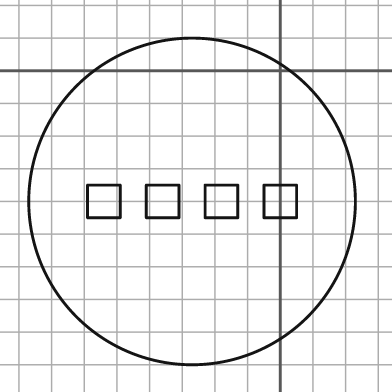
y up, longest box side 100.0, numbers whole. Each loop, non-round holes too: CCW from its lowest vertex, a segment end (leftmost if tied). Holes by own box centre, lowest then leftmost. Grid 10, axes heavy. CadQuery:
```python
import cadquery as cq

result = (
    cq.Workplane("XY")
    .moveTo(-27.0, -40.0)
    .circle(50.0)
    .moveTo(-59.0, -45.0)
    .lineTo(-49.0, -45.0)
    .lineTo(-49.0, -35.0)
    .lineTo(-59.0, -35.0)
    .close()
    .moveTo(-41.0, -45.0)
    .lineTo(-31.0, -45.0)
    .lineTo(-31.0, -35.0)
    .lineTo(-41.0, -35.0)
    .close()
    .moveTo(-23.0, -45.0)
    .lineTo(-13.0, -45.0)
    .lineTo(-13.0, -35.0)
    .lineTo(-23.0, -35.0)
    .close()
    .moveTo(-5.0, -45.0)
    .lineTo(5.0, -45.0)
    .lineTo(5.0, -35.0)
    .lineTo(-5.0, -35.0)
    .close()
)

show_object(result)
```